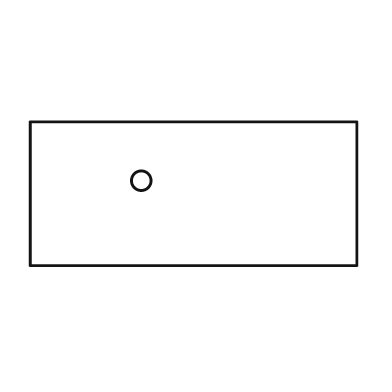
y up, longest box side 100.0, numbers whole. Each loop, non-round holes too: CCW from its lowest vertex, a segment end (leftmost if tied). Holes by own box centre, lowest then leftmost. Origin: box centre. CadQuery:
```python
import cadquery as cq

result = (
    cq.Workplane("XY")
    .moveTo(-50.0, -22.0)
    .lineTo(50.0, -22.0)
    .lineTo(50.0, 22.0)
    .lineTo(-50.0, 22.0)
    .close()
    .moveTo(-16.0, 4.0)
    .circle(3.0)
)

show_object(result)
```